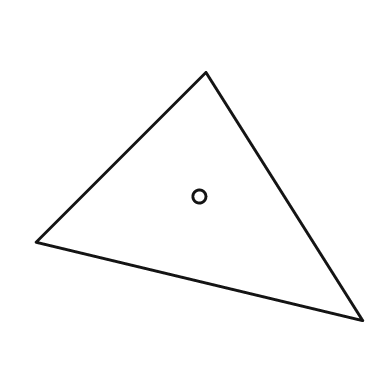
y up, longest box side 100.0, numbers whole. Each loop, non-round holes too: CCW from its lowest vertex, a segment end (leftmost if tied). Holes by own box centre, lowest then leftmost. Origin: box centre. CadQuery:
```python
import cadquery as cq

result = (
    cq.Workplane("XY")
    .moveTo(50.0, -38.0)
    .lineTo(2.0, 38.0)
    .lineTo(-50.0, -14.0)
    .close()
    .moveTo(0.0, 0.0)
    .circle(2.0)
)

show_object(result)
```